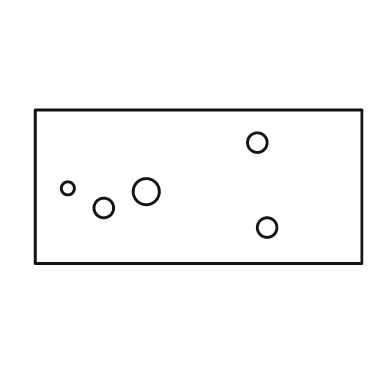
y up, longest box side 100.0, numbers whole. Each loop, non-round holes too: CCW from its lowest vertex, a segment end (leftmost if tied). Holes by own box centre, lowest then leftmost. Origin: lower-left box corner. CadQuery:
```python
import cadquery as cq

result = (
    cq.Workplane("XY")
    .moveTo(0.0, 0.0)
    .lineTo(100.0, 0.0)
    .lineTo(100.0, 47.0)
    .lineTo(0.0, 47.0)
    .close()
    .moveTo(71.0, 11.0)
    .circle(3.0)
    .moveTo(21.0, 17.0)
    .circle(3.0)
    .moveTo(34.0, 22.0)
    .circle(4.0)
    .moveTo(10.0, 23.0)
    .circle(2.0)
    .moveTo(68.0, 37.0)
    .circle(3.0)
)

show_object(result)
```